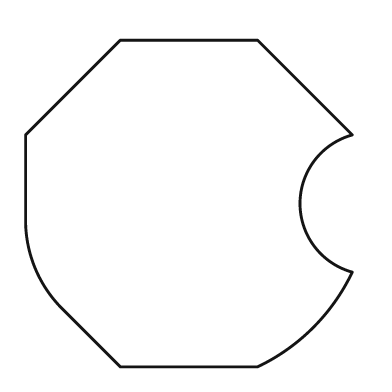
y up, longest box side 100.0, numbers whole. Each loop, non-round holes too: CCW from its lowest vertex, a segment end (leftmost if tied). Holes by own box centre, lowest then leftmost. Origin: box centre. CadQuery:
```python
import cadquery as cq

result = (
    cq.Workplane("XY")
    .moveTo(-21.0, -50.0)
    .lineTo(21.0, -50.0)
    .threePointArc((38.0, -38.0), (50.0, -21.0))
    .threePointArc((34.0, 0.0), (50.0, 21.0))
    .lineTo(21.0, 50.0)
    .lineTo(-21.0, 50.0)
    .lineTo(-50.0, 21.0)
    .lineTo(-50.0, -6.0)
    .threePointArc((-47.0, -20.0), (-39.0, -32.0))
    .close()
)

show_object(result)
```